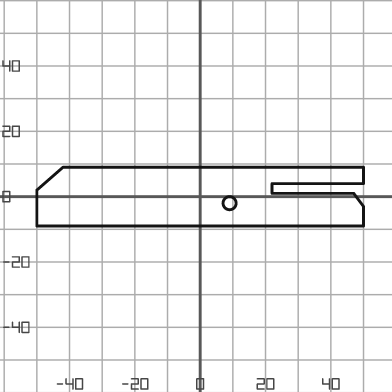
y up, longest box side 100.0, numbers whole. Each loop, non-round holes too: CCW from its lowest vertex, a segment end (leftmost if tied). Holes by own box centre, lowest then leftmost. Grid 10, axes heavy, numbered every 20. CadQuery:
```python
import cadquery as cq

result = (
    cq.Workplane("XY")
    .moveTo(-50.0, -9.0)
    .lineTo(50.0, -9.0)
    .lineTo(50.0, -3.0)
    .lineTo(47.0, 1.0)
    .lineTo(22.0, 1.0)
    .lineTo(22.0, 4.0)
    .lineTo(50.0, 4.0)
    .lineTo(50.0, 9.0)
    .lineTo(-42.0, 9.0)
    .lineTo(-50.0, 2.0)
    .close()
    .moveTo(9.0, -2.0)
    .circle(2.0)
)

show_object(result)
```